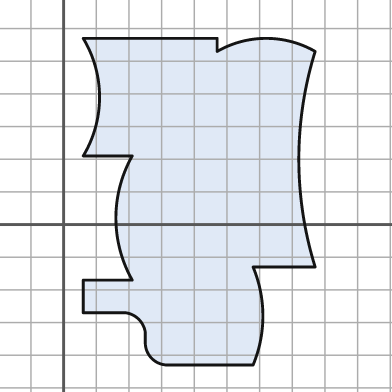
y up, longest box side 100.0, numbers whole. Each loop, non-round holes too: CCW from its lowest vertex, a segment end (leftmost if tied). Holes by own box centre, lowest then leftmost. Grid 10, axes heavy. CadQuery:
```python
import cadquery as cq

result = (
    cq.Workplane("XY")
    .moveTo(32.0, -43.0)
    .lineTo(58.0, -43.0)
    .threePointArc((61.0, -28.0), (58.0, -13.0))
    .lineTo(77.0, -13.0)
    .threePointArc((72.0, 20.0), (77.0, 53.0))
    .threePointArc((62.0, 57.0), (47.0, 53.0))
    .lineTo(47.0, 57.0)
    .lineTo(6.0, 57.0)
    .threePointArc((11.0, 39.0), (6.0, 21.0))
    .lineTo(21.0, 21.0)
    .threePointArc((16.0, 2.0), (21.0, -17.0))
    .lineTo(6.0, -17.0)
    .lineTo(6.0, -27.0)
    .lineTo(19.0, -27.0)
    .threePointArc((23.0, -29.0), (25.0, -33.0))
    .lineTo(25.0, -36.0)
    .threePointArc((27.0, -41.0), (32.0, -43.0))
    .close()
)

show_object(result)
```